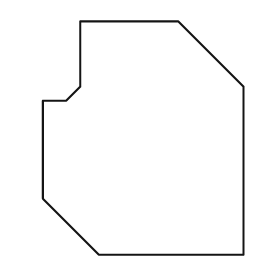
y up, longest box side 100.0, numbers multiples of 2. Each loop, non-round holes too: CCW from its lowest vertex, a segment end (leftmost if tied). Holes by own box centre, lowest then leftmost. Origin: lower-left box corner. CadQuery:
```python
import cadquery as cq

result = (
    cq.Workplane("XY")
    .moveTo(24.0, 0.0)
    .lineTo(86.0, 0.0)
    .lineTo(86.0, 72.0)
    .lineTo(58.0, 100.0)
    .lineTo(16.0, 100.0)
    .lineTo(16.0, 72.0)
    .lineTo(10.0, 66.0)
    .lineTo(0.0, 66.0)
    .lineTo(0.0, 24.0)
    .close()
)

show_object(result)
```